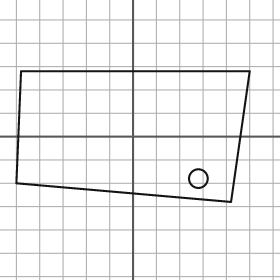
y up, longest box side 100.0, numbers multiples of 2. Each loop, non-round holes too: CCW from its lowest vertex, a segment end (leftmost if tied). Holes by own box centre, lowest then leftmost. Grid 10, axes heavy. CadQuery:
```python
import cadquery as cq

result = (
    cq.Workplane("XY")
    .moveTo(42.0, -28.0)
    .lineTo(50.0, 28.0)
    .lineTo(-48.0, 28.0)
    .lineTo(-50.0, -20.0)
    .close()
    .moveTo(28.0, -18.0)
    .circle(4.0)
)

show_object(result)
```